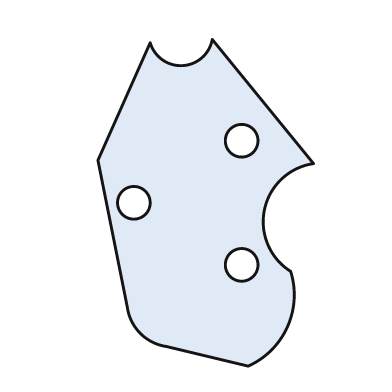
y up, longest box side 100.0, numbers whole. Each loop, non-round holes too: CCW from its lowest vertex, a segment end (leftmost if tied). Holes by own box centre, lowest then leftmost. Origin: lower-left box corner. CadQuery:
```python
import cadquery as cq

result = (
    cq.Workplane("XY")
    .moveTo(46.0, 0.0)
    .threePointArc((58.0, 12.0), (59.0, 29.0))
    .threePointArc((51.0, 48.0), (66.0, 62.0))
    .lineTo(35.0, 100.0)
    .threePointArc((26.0, 92.0), (16.0, 99.0))
    .lineTo(0.0, 63.0)
    .lineTo(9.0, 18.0)
    .threePointArc((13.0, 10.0), (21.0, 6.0))
    .close()
    .moveTo(44.0, 31.0)
    .circle(5.0)
    .moveTo(11.0, 50.0)
    .circle(5.0)
    .moveTo(44.0, 69.0)
    .circle(5.0)
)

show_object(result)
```